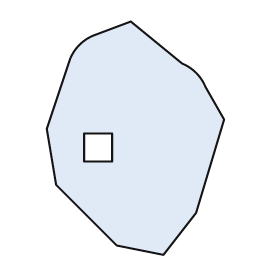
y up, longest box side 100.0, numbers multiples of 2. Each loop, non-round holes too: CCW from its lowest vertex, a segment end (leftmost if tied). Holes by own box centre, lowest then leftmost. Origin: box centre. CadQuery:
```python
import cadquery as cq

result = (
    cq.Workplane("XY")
    .moveTo(12.0, -50.0)
    .lineTo(26.0, -32.0)
    .lineTo(38.0, 8.0)
    .lineTo(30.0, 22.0)
    .threePointArc((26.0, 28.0), (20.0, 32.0))
    .lineTo(-2.0, 50.0)
    .lineTo(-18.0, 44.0)
    .threePointArc((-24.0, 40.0), (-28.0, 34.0))
    .lineTo(-38.0, 4.0)
    .lineTo(-34.0, -20.0)
    .lineTo(-8.0, -46.0)
    .close()
    .moveTo(-22.0, -10.0)
    .lineTo(-10.0, -10.0)
    .lineTo(-10.0, 2.0)
    .lineTo(-22.0, 2.0)
    .close()
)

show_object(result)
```